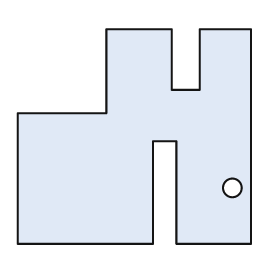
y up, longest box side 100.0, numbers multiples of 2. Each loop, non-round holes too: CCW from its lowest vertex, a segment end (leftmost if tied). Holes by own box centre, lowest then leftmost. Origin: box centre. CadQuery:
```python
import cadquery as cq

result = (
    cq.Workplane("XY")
    .moveTo(-50.0, -46.0)
    .lineTo(8.0, -46.0)
    .lineTo(8.0, -2.0)
    .lineTo(18.0, -2.0)
    .lineTo(18.0, -46.0)
    .lineTo(50.0, -46.0)
    .lineTo(50.0, 46.0)
    .lineTo(28.0, 46.0)
    .lineTo(28.0, 20.0)
    .lineTo(16.0, 20.0)
    .lineTo(16.0, 46.0)
    .lineTo(-12.0, 46.0)
    .lineTo(-12.0, 10.0)
    .lineTo(-50.0, 10.0)
    .close()
    .moveTo(42.0, -22.0)
    .circle(4.0)
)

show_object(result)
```